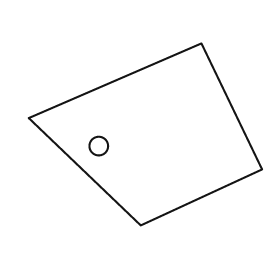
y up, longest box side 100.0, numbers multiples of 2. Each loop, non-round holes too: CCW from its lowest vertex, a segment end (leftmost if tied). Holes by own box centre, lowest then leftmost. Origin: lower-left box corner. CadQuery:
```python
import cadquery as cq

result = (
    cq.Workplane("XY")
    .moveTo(48.0, 0.0)
    .lineTo(100.0, 24.0)
    .lineTo(74.0, 78.0)
    .lineTo(0.0, 46.0)
    .close()
    .moveTo(30.0, 34.0)
    .circle(4.0)
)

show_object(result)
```